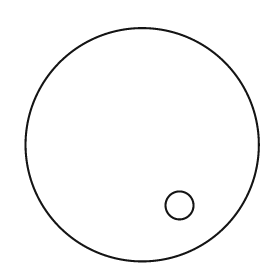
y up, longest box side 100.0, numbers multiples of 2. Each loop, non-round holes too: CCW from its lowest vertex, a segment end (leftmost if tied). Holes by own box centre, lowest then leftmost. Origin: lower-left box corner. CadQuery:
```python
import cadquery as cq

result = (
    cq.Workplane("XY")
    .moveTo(50.0, 50.0)
    .circle(50.0)
    .moveTo(66.0, 24.0)
    .circle(6.0)
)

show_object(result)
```